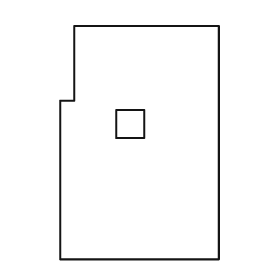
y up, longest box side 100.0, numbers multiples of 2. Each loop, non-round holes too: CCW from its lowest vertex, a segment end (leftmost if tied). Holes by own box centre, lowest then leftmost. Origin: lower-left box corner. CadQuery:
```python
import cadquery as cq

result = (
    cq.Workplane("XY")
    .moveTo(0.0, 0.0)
    .lineTo(68.0, 0.0)
    .lineTo(68.0, 100.0)
    .lineTo(6.0, 100.0)
    .lineTo(6.0, 68.0)
    .lineTo(0.0, 68.0)
    .close()
    .moveTo(24.0, 52.0)
    .lineTo(36.0, 52.0)
    .lineTo(36.0, 64.0)
    .lineTo(24.0, 64.0)
    .close()
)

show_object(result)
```